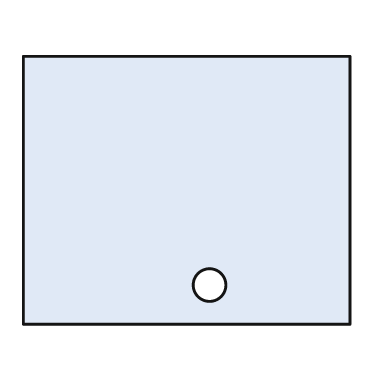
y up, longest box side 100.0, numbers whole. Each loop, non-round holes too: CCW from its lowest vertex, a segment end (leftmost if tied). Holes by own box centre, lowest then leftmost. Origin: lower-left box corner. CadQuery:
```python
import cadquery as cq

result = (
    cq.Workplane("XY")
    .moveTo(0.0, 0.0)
    .lineTo(100.0, 0.0)
    .lineTo(100.0, 82.0)
    .lineTo(0.0, 82.0)
    .close()
    .moveTo(57.0, 12.0)
    .circle(5.0)
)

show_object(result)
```